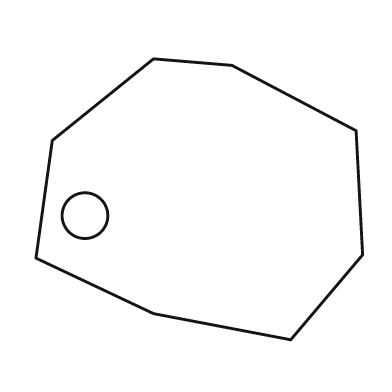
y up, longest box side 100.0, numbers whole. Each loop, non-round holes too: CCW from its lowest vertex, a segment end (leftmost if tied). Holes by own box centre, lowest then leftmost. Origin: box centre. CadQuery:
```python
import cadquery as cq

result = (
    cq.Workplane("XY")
    .moveTo(28.0, -43.0)
    .lineTo(50.0, -17.0)
    .lineTo(48.0, 21.0)
    .lineTo(10.0, 41.0)
    .lineTo(-14.0, 43.0)
    .lineTo(-45.0, 18.0)
    .lineTo(-50.0, -18.0)
    .lineTo(-14.0, -35.0)
    .close()
    .moveTo(-35.0, -5.0)
    .circle(7.0)
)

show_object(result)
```